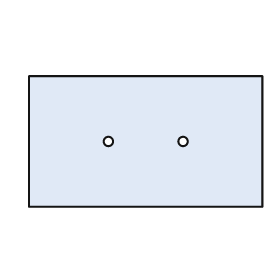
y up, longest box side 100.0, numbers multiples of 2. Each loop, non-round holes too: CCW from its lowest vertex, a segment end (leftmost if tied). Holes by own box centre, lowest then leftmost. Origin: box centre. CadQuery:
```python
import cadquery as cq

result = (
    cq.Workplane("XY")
    .moveTo(-50.0, -28.0)
    .lineTo(50.0, -28.0)
    .lineTo(50.0, 28.0)
    .lineTo(-50.0, 28.0)
    .close()
    .moveTo(-16.0, 0.0)
    .circle(2.0)
    .moveTo(16.0, 0.0)
    .circle(2.0)
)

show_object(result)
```